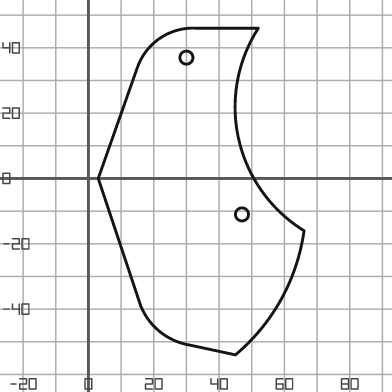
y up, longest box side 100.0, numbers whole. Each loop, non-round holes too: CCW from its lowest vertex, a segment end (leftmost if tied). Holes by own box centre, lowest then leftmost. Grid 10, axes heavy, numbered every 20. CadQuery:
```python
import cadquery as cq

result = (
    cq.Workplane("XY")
    .moveTo(45.0, -54.0)
    .threePointArc((59.0, -37.0), (66.0, -16.0))
    .threePointArc((46.0, 12.0), (52.0, 46.0))
    .lineTo(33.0, 46.0)
    .threePointArc((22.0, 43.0), (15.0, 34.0))
    .lineTo(3.0, 0.0)
    .lineTo(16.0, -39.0)
    .threePointArc((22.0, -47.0), (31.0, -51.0))
    .close()
    .moveTo(47.0, -11.0)
    .circle(2.0)
    .moveTo(30.0, 37.0)
    .circle(2.0)
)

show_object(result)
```